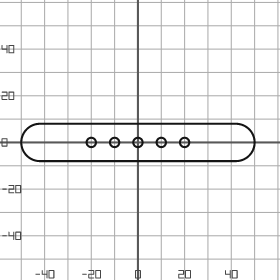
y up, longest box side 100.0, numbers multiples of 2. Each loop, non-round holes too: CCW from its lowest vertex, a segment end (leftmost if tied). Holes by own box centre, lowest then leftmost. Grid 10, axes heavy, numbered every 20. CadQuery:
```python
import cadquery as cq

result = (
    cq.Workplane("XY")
    .moveTo(-42.0, -8.0)
    .lineTo(42.0, -8.0)
    .threePointArc((50.0, 0.0), (42.0, 8.0))
    .lineTo(-42.0, 8.0)
    .threePointArc((-50.0, 0.0), (-42.0, -8.0))
    .close()
    .moveTo(-20.0, 0.0)
    .circle(2.0)
    .moveTo(-10.0, 0.0)
    .circle(2.0)
    .moveTo(0.0, 0.0)
    .circle(2.0)
    .moveTo(10.0, 0.0)
    .circle(2.0)
    .moveTo(20.0, 0.0)
    .circle(2.0)
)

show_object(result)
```